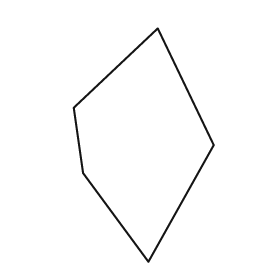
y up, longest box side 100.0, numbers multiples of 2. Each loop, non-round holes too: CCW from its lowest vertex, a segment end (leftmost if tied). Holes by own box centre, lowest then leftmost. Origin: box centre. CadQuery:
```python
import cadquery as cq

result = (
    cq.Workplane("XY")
    .moveTo(2.0, -50.0)
    .lineTo(30.0, 0.0)
    .lineTo(6.0, 50.0)
    .lineTo(-30.0, 16.0)
    .lineTo(-26.0, -12.0)
    .close()
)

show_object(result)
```